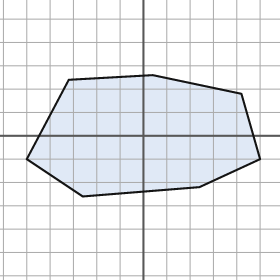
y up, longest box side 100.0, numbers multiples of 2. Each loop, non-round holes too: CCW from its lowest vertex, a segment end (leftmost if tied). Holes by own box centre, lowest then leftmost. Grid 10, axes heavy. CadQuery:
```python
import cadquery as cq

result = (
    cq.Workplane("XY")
    .moveTo(-26.0, -26.0)
    .lineTo(24.0, -22.0)
    .lineTo(50.0, -10.0)
    .lineTo(42.0, 18.0)
    .lineTo(4.0, 26.0)
    .lineTo(-32.0, 24.0)
    .lineTo(-50.0, -10.0)
    .close()
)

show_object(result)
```